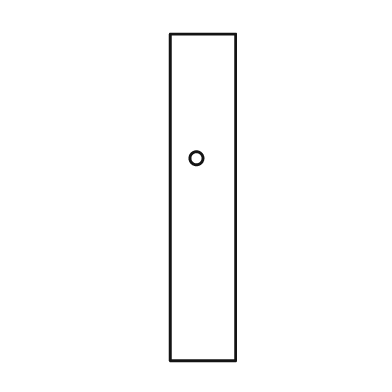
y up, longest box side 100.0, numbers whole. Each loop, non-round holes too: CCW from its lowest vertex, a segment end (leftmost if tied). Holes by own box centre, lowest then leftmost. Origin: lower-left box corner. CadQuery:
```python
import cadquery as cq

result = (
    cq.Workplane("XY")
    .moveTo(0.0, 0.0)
    .lineTo(20.0, 0.0)
    .lineTo(20.0, 100.0)
    .lineTo(0.0, 100.0)
    .close()
    .moveTo(8.0, 62.0)
    .circle(2.0)
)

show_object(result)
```